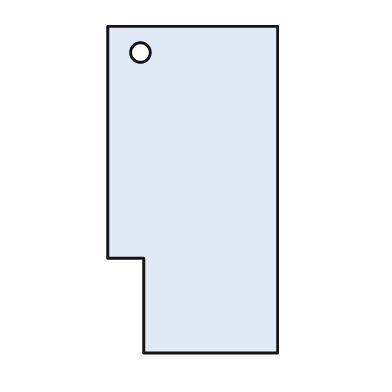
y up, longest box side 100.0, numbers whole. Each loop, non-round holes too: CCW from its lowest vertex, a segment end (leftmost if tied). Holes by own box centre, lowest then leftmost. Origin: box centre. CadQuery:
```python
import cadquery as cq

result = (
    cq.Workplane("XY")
    .moveTo(-15.0, -50.0)
    .lineTo(26.0, -50.0)
    .lineTo(26.0, 50.0)
    .lineTo(-26.0, 50.0)
    .lineTo(-26.0, -21.0)
    .lineTo(-15.0, -21.0)
    .close()
    .moveTo(-16.0, 42.0)
    .circle(3.0)
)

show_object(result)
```